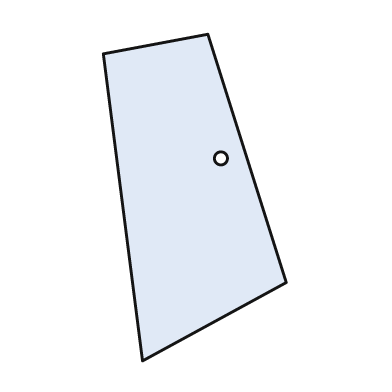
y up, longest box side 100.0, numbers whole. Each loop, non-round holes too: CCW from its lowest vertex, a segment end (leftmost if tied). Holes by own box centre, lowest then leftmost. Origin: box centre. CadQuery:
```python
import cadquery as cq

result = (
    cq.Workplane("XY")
    .moveTo(-16.0, -50.0)
    .lineTo(28.0, -26.0)
    .lineTo(4.0, 50.0)
    .lineTo(-28.0, 44.0)
    .close()
    .moveTo(8.0, 12.0)
    .circle(2.0)
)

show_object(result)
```